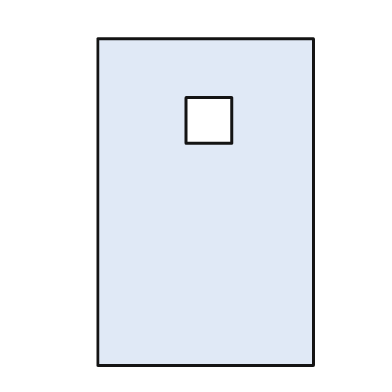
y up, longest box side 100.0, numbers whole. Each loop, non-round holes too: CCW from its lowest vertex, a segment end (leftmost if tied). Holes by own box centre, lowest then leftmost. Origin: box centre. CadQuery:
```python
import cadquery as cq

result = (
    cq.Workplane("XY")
    .moveTo(-33.0, -50.0)
    .lineTo(33.0, -50.0)
    .lineTo(33.0, 50.0)
    .lineTo(-33.0, 50.0)
    .close()
    .moveTo(-6.0, 18.0)
    .lineTo(8.0, 18.0)
    .lineTo(8.0, 32.0)
    .lineTo(-6.0, 32.0)
    .close()
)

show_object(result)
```